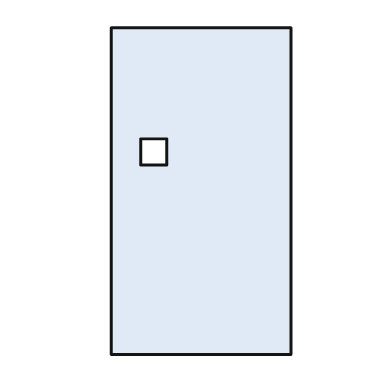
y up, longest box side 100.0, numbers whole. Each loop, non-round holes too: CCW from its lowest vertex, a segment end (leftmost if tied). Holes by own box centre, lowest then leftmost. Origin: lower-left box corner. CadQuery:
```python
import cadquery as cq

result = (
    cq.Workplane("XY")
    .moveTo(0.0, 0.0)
    .lineTo(55.0, 0.0)
    .lineTo(55.0, 100.0)
    .lineTo(0.0, 100.0)
    .close()
    .moveTo(9.0, 58.0)
    .lineTo(17.0, 58.0)
    .lineTo(17.0, 66.0)
    .lineTo(9.0, 66.0)
    .close()
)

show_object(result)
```